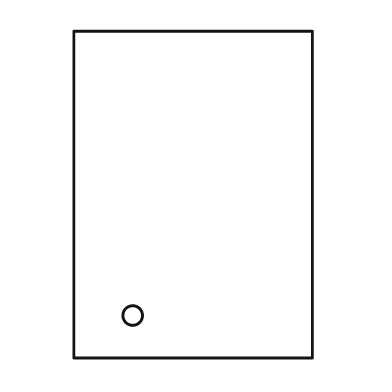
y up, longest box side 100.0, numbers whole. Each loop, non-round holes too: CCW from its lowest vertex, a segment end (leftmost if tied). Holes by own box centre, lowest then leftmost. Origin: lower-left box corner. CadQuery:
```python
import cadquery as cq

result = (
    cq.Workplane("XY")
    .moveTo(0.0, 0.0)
    .lineTo(73.0, 0.0)
    .lineTo(73.0, 100.0)
    .lineTo(0.0, 100.0)
    .close()
    .moveTo(18.0, 13.0)
    .circle(3.0)
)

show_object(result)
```